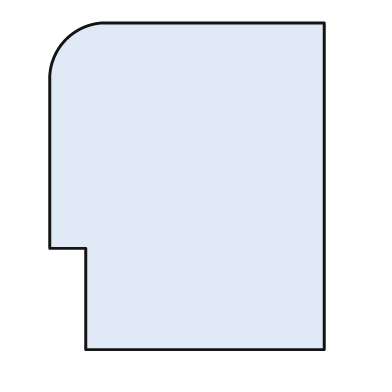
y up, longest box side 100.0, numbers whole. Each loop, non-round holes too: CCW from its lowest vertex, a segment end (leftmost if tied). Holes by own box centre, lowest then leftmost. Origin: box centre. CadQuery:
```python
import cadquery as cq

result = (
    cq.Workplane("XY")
    .moveTo(-31.0, -50.0)
    .lineTo(42.0, -50.0)
    .lineTo(42.0, 50.0)
    .lineTo(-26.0, 50.0)
    .threePointArc((-37.0, 45.0), (-42.0, 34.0))
    .lineTo(-42.0, -19.0)
    .lineTo(-31.0, -19.0)
    .close()
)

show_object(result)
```